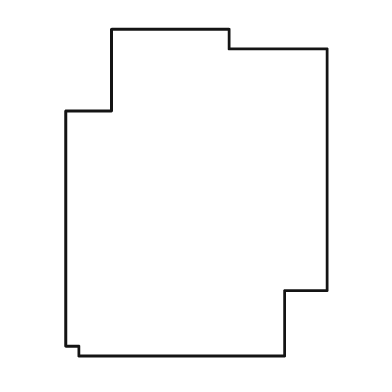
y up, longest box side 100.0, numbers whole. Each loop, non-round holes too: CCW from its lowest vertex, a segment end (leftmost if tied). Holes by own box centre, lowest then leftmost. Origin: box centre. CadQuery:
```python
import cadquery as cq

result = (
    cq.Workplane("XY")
    .moveTo(-36.0, -50.0)
    .lineTo(27.0, -50.0)
    .lineTo(27.0, -30.0)
    .lineTo(40.0, -30.0)
    .lineTo(40.0, 44.0)
    .lineTo(10.0, 44.0)
    .lineTo(10.0, 50.0)
    .lineTo(-26.0, 50.0)
    .lineTo(-26.0, 25.0)
    .lineTo(-40.0, 25.0)
    .lineTo(-40.0, -47.0)
    .lineTo(-36.0, -47.0)
    .close()
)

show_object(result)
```